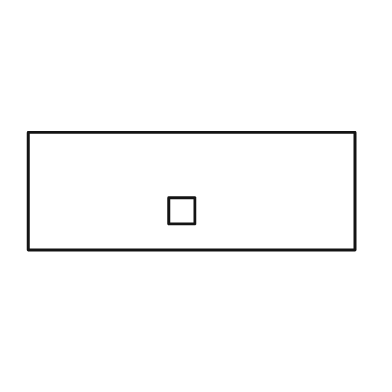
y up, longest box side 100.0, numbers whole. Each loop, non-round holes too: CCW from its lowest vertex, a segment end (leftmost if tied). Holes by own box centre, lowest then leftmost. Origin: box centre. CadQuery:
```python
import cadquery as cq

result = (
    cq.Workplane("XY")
    .moveTo(-50.0, -18.0)
    .lineTo(50.0, -18.0)
    .lineTo(50.0, 18.0)
    .lineTo(-50.0, 18.0)
    .close()
    .moveTo(-7.0, -10.0)
    .lineTo(1.0, -10.0)
    .lineTo(1.0, -2.0)
    .lineTo(-7.0, -2.0)
    .close()
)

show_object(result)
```